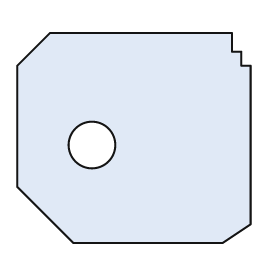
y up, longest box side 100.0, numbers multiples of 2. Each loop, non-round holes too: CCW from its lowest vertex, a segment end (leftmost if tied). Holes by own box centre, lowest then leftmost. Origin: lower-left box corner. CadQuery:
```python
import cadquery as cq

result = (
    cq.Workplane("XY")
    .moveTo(24.0, 0.0)
    .lineTo(88.0, 0.0)
    .lineTo(100.0, 8.0)
    .lineTo(100.0, 76.0)
    .lineTo(96.0, 76.0)
    .lineTo(96.0, 82.0)
    .lineTo(92.0, 82.0)
    .lineTo(92.0, 90.0)
    .lineTo(14.0, 90.0)
    .lineTo(0.0, 76.0)
    .lineTo(0.0, 24.0)
    .close()
    .moveTo(32.0, 42.0)
    .circle(10.0)
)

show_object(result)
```